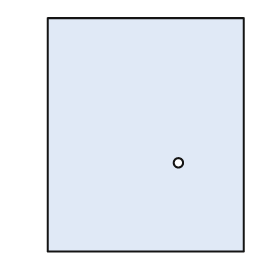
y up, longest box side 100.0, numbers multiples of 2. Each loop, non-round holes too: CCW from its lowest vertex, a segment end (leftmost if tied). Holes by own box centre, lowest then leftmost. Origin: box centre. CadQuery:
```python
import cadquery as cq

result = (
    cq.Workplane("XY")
    .moveTo(-42.0, -50.0)
    .lineTo(42.0, -50.0)
    .lineTo(42.0, 50.0)
    .lineTo(-42.0, 50.0)
    .close()
    .moveTo(14.0, -12.0)
    .circle(2.0)
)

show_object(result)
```